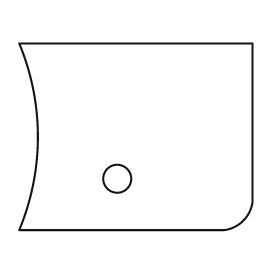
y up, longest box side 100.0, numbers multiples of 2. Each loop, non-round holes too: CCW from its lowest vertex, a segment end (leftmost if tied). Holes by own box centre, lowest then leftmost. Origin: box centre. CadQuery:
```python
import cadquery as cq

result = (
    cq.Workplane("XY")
    .moveTo(-50.0, -40.0)
    .lineTo(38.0, -40.0)
    .threePointArc((46.0, -36.0), (50.0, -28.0))
    .lineTo(50.0, 40.0)
    .lineTo(-50.0, 40.0)
    .threePointArc((-42.0, 0.0), (-50.0, -40.0))
    .close()
    .moveTo(-8.0, -18.0)
    .circle(6.0)
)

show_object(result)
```